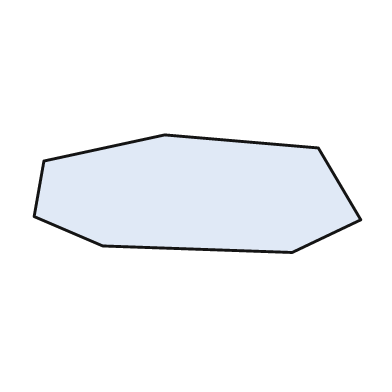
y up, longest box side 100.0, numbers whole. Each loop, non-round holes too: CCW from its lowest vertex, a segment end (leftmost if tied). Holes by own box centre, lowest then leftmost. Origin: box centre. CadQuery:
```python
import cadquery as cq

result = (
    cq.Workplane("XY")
    .moveTo(29.0, -18.0)
    .lineTo(50.0, -8.0)
    .lineTo(37.0, 14.0)
    .lineTo(-10.0, 18.0)
    .lineTo(-47.0, 10.0)
    .lineTo(-50.0, -7.0)
    .lineTo(-29.0, -16.0)
    .close()
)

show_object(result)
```